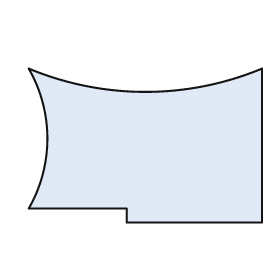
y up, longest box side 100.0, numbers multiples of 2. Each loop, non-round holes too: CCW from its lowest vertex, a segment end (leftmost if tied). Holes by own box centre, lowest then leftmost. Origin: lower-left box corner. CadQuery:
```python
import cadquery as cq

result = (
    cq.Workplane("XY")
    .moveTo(42.0, 0.0)
    .lineTo(100.0, 0.0)
    .lineTo(100.0, 66.0)
    .threePointArc((50.0, 56.0), (0.0, 66.0))
    .threePointArc((8.0, 36.0), (0.0, 6.0))
    .lineTo(42.0, 6.0)
    .close()
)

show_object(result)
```